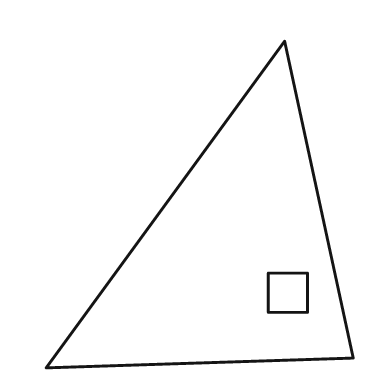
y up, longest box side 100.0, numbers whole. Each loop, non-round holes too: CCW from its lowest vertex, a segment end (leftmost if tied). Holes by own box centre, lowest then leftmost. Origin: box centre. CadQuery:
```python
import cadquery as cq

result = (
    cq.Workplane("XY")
    .moveTo(-47.0, -50.0)
    .lineTo(47.0, -47.0)
    .lineTo(26.0, 50.0)
    .close()
    .moveTo(21.0, -33.0)
    .lineTo(33.0, -33.0)
    .lineTo(33.0, -21.0)
    .lineTo(21.0, -21.0)
    .close()
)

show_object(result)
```